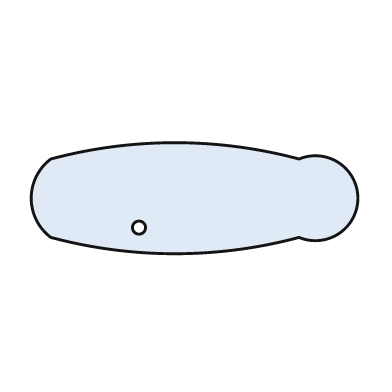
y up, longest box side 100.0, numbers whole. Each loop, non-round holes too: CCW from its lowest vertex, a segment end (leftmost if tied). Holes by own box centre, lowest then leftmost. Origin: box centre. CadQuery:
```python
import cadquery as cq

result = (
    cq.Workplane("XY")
    .moveTo(-44.0, -12.0)
    .threePointArc((-6.0, -17.0), (32.0, -12.0))
    .threePointArc((50.0, 0.0), (32.0, 12.0))
    .threePointArc((-6.0, 17.0), (-44.0, 12.0))
    .threePointArc((-50.0, 0.0), (-44.0, -12.0))
    .close()
    .moveTo(-17.0, -9.0)
    .circle(2.0)
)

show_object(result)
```